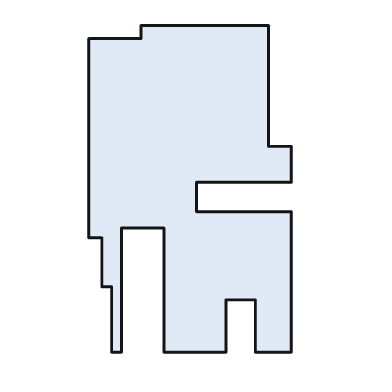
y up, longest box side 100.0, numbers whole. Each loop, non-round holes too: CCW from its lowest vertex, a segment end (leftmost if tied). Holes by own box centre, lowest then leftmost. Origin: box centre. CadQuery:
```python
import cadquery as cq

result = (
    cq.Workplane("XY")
    .moveTo(-24.0, -50.0)
    .lineTo(-21.0, -50.0)
    .lineTo(-21.0, -12.0)
    .lineTo(-8.0, -12.0)
    .lineTo(-8.0, -50.0)
    .lineTo(11.0, -50.0)
    .lineTo(11.0, -34.0)
    .lineTo(20.0, -34.0)
    .lineTo(20.0, -50.0)
    .lineTo(31.0, -50.0)
    .lineTo(31.0, -7.0)
    .lineTo(2.0, -7.0)
    .lineTo(2.0, 2.0)
    .lineTo(31.0, 2.0)
    .lineTo(31.0, 13.0)
    .lineTo(24.0, 13.0)
    .lineTo(24.0, 50.0)
    .lineTo(-15.0, 50.0)
    .lineTo(-15.0, 46.0)
    .lineTo(-31.0, 46.0)
    .lineTo(-31.0, -15.0)
    .lineTo(-27.0, -15.0)
    .lineTo(-27.0, -30.0)
    .lineTo(-24.0, -30.0)
    .close()
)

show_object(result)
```